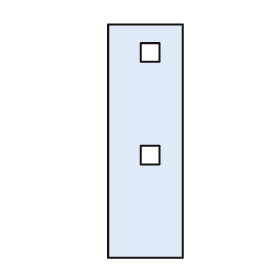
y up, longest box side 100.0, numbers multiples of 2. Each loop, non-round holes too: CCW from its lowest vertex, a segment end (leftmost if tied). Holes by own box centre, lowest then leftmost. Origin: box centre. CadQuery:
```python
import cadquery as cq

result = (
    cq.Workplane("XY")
    .moveTo(-16.0, -50.0)
    .lineTo(16.0, -50.0)
    .lineTo(16.0, 50.0)
    .lineTo(-16.0, 50.0)
    .close()
    .moveTo(-2.0, -10.0)
    .lineTo(6.0, -10.0)
    .lineTo(6.0, -2.0)
    .lineTo(-2.0, -2.0)
    .close()
    .moveTo(-2.0, 34.0)
    .lineTo(6.0, 34.0)
    .lineTo(6.0, 42.0)
    .lineTo(-2.0, 42.0)
    .close()
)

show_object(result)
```